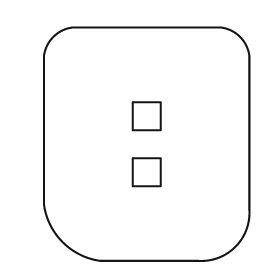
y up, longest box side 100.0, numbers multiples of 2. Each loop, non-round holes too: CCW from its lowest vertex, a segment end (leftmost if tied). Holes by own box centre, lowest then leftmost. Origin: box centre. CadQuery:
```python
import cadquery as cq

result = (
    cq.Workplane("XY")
    .moveTo(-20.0, -50.0)
    .lineTo(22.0, -50.0)
    .threePointArc((38.0, -44.0), (44.0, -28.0))
    .lineTo(44.0, 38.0)
    .threePointArc((40.0, 46.0), (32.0, 50.0))
    .lineTo(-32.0, 50.0)
    .threePointArc((-40.0, 46.0), (-44.0, 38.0))
    .lineTo(-44.0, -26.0)
    .threePointArc((-36.0, -42.0), (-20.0, -50.0))
    .close()
    .moveTo(-6.0, -18.0)
    .lineTo(6.0, -18.0)
    .lineTo(6.0, -6.0)
    .lineTo(-6.0, -6.0)
    .close()
    .moveTo(-6.0, 6.0)
    .lineTo(6.0, 6.0)
    .lineTo(6.0, 18.0)
    .lineTo(-6.0, 18.0)
    .close()
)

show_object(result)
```